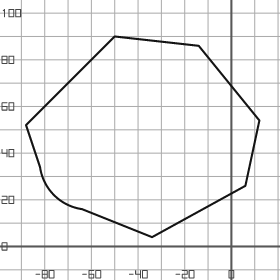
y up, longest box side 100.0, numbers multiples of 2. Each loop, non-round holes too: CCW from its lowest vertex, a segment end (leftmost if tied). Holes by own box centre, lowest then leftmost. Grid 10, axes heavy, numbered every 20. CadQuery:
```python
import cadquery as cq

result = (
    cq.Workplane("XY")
    .moveTo(-34.0, 4.0)
    .lineTo(6.0, 26.0)
    .lineTo(12.0, 54.0)
    .lineTo(-14.0, 86.0)
    .lineTo(-50.0, 90.0)
    .lineTo(-88.0, 52.0)
    .lineTo(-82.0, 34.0)
    .threePointArc((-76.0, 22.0), (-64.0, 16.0))
    .close()
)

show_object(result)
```